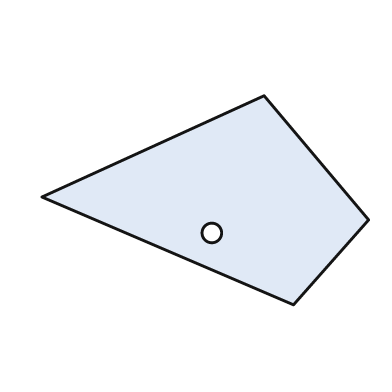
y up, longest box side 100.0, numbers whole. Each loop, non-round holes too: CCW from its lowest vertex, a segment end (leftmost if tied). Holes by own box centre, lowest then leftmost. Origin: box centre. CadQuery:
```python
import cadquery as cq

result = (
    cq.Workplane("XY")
    .moveTo(27.0, -32.0)
    .lineTo(50.0, -6.0)
    .lineTo(18.0, 32.0)
    .lineTo(-50.0, 1.0)
    .close()
    .moveTo(2.0, -10.0)
    .circle(3.0)
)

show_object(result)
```